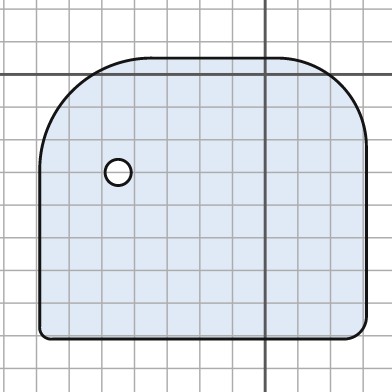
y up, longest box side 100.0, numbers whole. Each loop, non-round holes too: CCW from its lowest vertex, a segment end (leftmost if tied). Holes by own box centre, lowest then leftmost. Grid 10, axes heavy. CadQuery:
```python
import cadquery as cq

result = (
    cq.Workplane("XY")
    .moveTo(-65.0, -81.0)
    .lineTo(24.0, -81.0)
    .threePointArc((29.0, -79.0), (31.0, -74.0))
    .lineTo(31.0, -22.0)
    .threePointArc((23.0, -3.0), (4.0, 5.0))
    .lineTo(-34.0, 5.0)
    .threePointArc((-59.0, -5.0), (-69.0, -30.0))
    .lineTo(-69.0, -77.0)
    .threePointArc((-68.0, -80.0), (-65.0, -81.0))
    .close()
    .moveTo(-45.0, -30.0)
    .circle(4.0)
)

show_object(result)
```